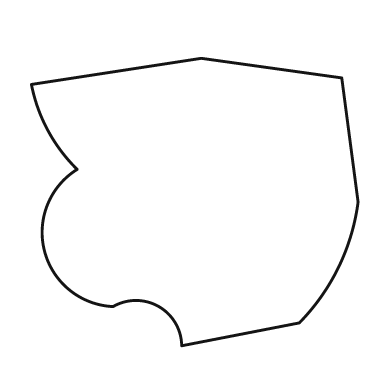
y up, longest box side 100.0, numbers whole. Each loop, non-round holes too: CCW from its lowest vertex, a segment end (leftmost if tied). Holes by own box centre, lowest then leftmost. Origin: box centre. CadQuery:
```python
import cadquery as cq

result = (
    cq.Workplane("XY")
    .moveTo(-4.0, -44.0)
    .lineTo(32.0, -37.0)
    .threePointArc((44.0, -20.0), (50.0, 0.0))
    .lineTo(45.0, 38.0)
    .lineTo(2.0, 44.0)
    .lineTo(-50.0, 36.0)
    .threePointArc((-45.0, 22.0), (-36.0, 10.0))
    .threePointArc((-46.0, -15.0), (-25.0, -32.0))
    .threePointArc((-11.0, -32.0), (-4.0, -44.0))
    .close()
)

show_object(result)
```